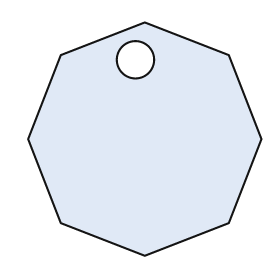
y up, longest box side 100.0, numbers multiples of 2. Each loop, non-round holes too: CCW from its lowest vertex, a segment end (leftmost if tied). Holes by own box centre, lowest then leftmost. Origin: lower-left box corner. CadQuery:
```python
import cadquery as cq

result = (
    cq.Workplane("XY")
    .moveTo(50.0, 0.0)
    .lineTo(86.0, 14.0)
    .lineTo(100.0, 50.0)
    .lineTo(86.0, 86.0)
    .lineTo(50.0, 100.0)
    .lineTo(14.0, 86.0)
    .lineTo(0.0, 50.0)
    .lineTo(14.0, 14.0)
    .close()
    .moveTo(46.0, 84.0)
    .circle(8.0)
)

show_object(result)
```